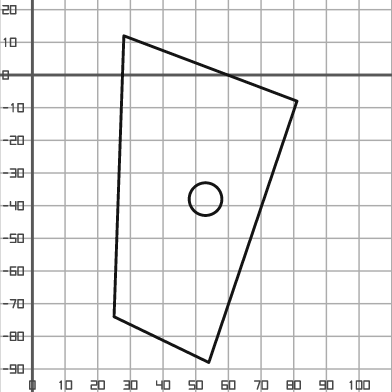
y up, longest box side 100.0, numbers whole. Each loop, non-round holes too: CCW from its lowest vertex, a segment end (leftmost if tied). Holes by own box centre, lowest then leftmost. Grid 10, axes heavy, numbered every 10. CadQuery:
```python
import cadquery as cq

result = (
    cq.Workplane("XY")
    .moveTo(54.0, -88.0)
    .lineTo(81.0, -8.0)
    .lineTo(28.0, 12.0)
    .lineTo(25.0, -74.0)
    .close()
    .moveTo(53.0, -38.0)
    .circle(5.0)
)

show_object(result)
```